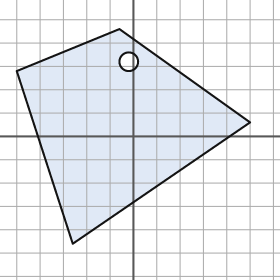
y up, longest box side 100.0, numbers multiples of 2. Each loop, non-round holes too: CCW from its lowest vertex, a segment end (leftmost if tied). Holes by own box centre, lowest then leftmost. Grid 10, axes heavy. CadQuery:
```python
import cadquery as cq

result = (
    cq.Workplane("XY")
    .moveTo(-26.0, -46.0)
    .lineTo(50.0, 6.0)
    .lineTo(-6.0, 46.0)
    .lineTo(-50.0, 28.0)
    .close()
    .moveTo(-2.0, 32.0)
    .circle(4.0)
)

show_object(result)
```